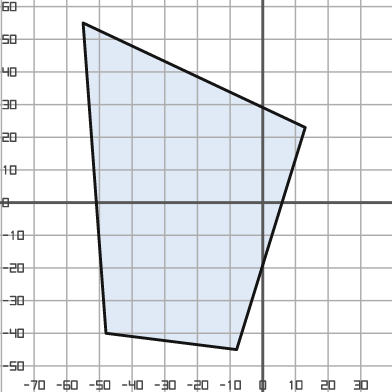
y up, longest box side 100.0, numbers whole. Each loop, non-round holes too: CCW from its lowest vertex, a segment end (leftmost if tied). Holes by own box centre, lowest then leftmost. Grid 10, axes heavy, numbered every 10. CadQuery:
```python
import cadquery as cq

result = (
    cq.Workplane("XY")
    .moveTo(-8.0, -45.0)
    .lineTo(13.0, 23.0)
    .lineTo(-55.0, 55.0)
    .lineTo(-48.0, -40.0)
    .close()
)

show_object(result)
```